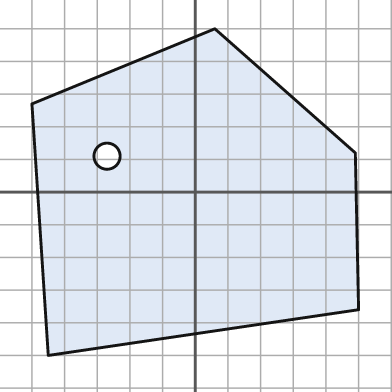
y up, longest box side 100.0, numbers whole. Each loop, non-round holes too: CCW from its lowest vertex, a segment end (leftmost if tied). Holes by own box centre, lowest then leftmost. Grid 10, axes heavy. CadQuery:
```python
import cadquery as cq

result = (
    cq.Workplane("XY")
    .moveTo(-45.0, -50.0)
    .lineTo(50.0, -36.0)
    .lineTo(49.0, 12.0)
    .lineTo(6.0, 50.0)
    .lineTo(-50.0, 27.0)
    .close()
    .moveTo(-27.0, 11.0)
    .circle(4.0)
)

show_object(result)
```